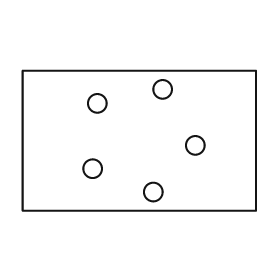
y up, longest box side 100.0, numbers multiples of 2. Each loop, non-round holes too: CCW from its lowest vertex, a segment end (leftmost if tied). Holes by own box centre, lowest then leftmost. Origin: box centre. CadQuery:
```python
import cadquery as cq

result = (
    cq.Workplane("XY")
    .moveTo(-50.0, -30.0)
    .lineTo(50.0, -30.0)
    .lineTo(50.0, 30.0)
    .lineTo(-50.0, 30.0)
    .close()
    .moveTo(6.0, -22.0)
    .circle(4.0)
    .moveTo(-20.0, -12.0)
    .circle(4.0)
    .moveTo(24.0, -2.0)
    .circle(4.0)
    .moveTo(-18.0, 16.0)
    .circle(4.0)
    .moveTo(10.0, 22.0)
    .circle(4.0)
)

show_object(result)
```